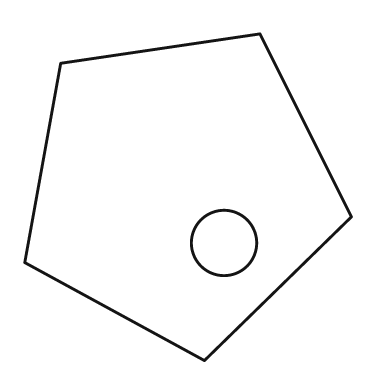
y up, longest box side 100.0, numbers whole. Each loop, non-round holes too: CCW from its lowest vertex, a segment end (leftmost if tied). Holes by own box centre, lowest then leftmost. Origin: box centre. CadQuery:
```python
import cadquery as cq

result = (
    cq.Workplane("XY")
    .moveTo(5.0, -50.0)
    .lineTo(50.0, -6.0)
    .lineTo(22.0, 50.0)
    .lineTo(-39.0, 41.0)
    .lineTo(-50.0, -20.0)
    .close()
    .moveTo(11.0, -14.0)
    .circle(10.0)
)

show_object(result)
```